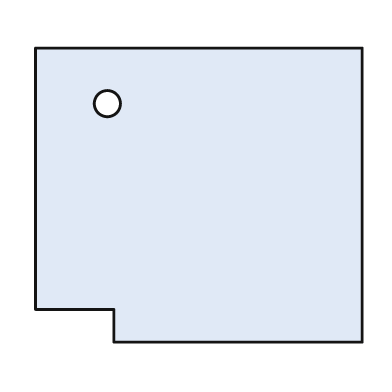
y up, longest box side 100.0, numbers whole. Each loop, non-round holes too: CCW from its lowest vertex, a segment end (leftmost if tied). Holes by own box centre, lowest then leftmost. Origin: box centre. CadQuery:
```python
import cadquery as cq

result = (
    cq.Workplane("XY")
    .moveTo(-26.0, -45.0)
    .lineTo(50.0, -45.0)
    .lineTo(50.0, 45.0)
    .lineTo(-50.0, 45.0)
    .lineTo(-50.0, -35.0)
    .lineTo(-26.0, -35.0)
    .close()
    .moveTo(-28.0, 28.0)
    .circle(4.0)
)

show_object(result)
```